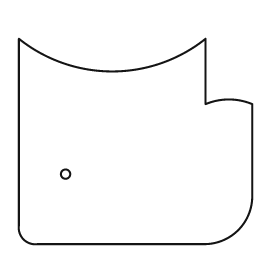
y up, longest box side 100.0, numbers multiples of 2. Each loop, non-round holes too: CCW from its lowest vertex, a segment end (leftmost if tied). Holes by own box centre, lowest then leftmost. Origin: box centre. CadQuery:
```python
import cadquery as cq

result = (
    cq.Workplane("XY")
    .moveTo(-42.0, -44.0)
    .lineTo(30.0, -44.0)
    .threePointArc((44.0, -38.0), (50.0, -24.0))
    .lineTo(50.0, 16.0)
    .threePointArc((40.0, 18.0), (30.0, 16.0))
    .lineTo(30.0, 44.0)
    .threePointArc((-10.0, 30.0), (-50.0, 44.0))
    .lineTo(-50.0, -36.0)
    .threePointArc((-48.0, -42.0), (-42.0, -44.0))
    .close()
    .moveTo(-30.0, -14.0)
    .circle(2.0)
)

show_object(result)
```